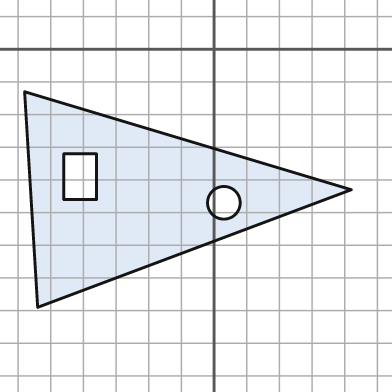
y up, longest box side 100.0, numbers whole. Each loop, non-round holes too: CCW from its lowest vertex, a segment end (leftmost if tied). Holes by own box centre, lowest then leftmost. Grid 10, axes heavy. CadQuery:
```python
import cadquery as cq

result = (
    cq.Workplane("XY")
    .moveTo(-54.0, -79.0)
    .lineTo(42.0, -43.0)
    .lineTo(-58.0, -13.0)
    .close()
    .moveTo(3.0, -47.0)
    .circle(5.0)
    .moveTo(-46.0, -46.0)
    .lineTo(-36.0, -46.0)
    .lineTo(-36.0, -32.0)
    .lineTo(-46.0, -32.0)
    .close()
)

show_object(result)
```